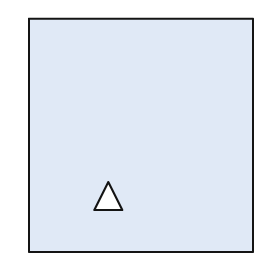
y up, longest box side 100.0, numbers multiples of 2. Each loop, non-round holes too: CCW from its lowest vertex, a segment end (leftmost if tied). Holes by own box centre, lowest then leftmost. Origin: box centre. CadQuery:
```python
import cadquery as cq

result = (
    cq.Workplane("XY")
    .moveTo(-48.0, -50.0)
    .lineTo(48.0, -50.0)
    .lineTo(48.0, 50.0)
    .lineTo(-48.0, 50.0)
    .close()
    .moveTo(-20.0, -32.0)
    .lineTo(-8.0, -32.0)
    .lineTo(-14.0, -20.0)
    .close()
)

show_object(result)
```